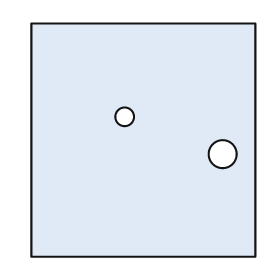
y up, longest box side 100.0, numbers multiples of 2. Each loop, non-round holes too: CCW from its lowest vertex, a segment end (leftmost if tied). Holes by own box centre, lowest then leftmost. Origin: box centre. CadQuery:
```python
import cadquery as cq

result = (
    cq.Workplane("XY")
    .moveTo(-48.0, -50.0)
    .lineTo(48.0, -50.0)
    .lineTo(48.0, 50.0)
    .lineTo(-48.0, 50.0)
    .close()
    .moveTo(34.0, -6.0)
    .circle(6.0)
    .moveTo(-8.0, 10.0)
    .circle(4.0)
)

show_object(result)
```